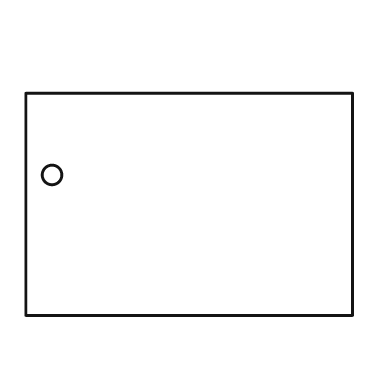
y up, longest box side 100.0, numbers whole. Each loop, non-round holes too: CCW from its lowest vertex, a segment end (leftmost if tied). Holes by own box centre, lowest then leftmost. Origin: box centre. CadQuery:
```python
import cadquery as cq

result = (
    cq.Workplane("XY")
    .moveTo(-50.0, -34.0)
    .lineTo(50.0, -34.0)
    .lineTo(50.0, 34.0)
    .lineTo(-50.0, 34.0)
    .close()
    .moveTo(-42.0, 9.0)
    .circle(3.0)
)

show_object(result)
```